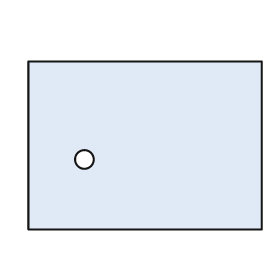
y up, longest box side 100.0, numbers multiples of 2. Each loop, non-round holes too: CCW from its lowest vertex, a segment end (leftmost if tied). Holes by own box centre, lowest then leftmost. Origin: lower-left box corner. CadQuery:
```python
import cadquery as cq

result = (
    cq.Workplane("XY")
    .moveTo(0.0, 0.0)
    .lineTo(100.0, 0.0)
    .lineTo(100.0, 72.0)
    .lineTo(0.0, 72.0)
    .close()
    .moveTo(24.0, 30.0)
    .circle(4.0)
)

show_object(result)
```